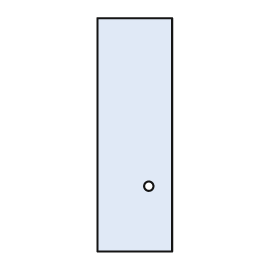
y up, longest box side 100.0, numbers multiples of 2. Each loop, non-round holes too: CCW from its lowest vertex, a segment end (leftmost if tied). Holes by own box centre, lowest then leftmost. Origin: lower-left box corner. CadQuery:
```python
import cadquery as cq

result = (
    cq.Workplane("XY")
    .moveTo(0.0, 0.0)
    .lineTo(32.0, 0.0)
    .lineTo(32.0, 100.0)
    .lineTo(0.0, 100.0)
    .close()
    .moveTo(22.0, 28.0)
    .circle(2.0)
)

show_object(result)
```